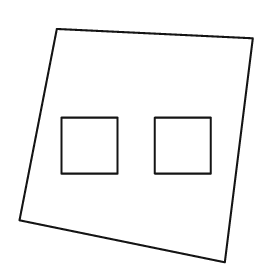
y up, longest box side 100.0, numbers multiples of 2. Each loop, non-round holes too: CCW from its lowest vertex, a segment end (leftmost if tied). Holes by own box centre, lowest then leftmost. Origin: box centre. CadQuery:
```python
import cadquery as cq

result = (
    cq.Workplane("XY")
    .moveTo(38.0, -50.0)
    .lineTo(50.0, 46.0)
    .lineTo(-34.0, 50.0)
    .lineTo(-50.0, -32.0)
    .close()
    .moveTo(-32.0, -12.0)
    .lineTo(-8.0, -12.0)
    .lineTo(-8.0, 12.0)
    .lineTo(-32.0, 12.0)
    .close()
    .moveTo(8.0, -12.0)
    .lineTo(32.0, -12.0)
    .lineTo(32.0, 12.0)
    .lineTo(8.0, 12.0)
    .close()
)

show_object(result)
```